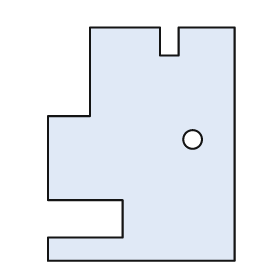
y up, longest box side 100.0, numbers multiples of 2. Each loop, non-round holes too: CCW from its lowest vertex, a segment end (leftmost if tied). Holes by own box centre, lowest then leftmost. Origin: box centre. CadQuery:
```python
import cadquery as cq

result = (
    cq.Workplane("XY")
    .moveTo(-40.0, -50.0)
    .lineTo(40.0, -50.0)
    .lineTo(40.0, 50.0)
    .lineTo(16.0, 50.0)
    .lineTo(16.0, 38.0)
    .lineTo(8.0, 38.0)
    .lineTo(8.0, 50.0)
    .lineTo(-22.0, 50.0)
    .lineTo(-22.0, 12.0)
    .lineTo(-40.0, 12.0)
    .lineTo(-40.0, -24.0)
    .lineTo(-8.0, -24.0)
    .lineTo(-8.0, -40.0)
    .lineTo(-40.0, -40.0)
    .close()
    .moveTo(22.0, 2.0)
    .circle(4.0)
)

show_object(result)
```